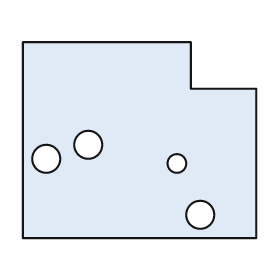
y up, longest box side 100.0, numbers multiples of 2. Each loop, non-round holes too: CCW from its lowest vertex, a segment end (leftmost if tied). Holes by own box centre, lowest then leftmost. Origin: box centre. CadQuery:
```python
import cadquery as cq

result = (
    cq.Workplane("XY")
    .moveTo(-50.0, -42.0)
    .lineTo(50.0, -42.0)
    .lineTo(50.0, 22.0)
    .lineTo(22.0, 22.0)
    .lineTo(22.0, 42.0)
    .lineTo(-50.0, 42.0)
    .close()
    .moveTo(26.0, -32.0)
    .circle(6.0)
    .moveTo(16.0, -10.0)
    .circle(4.0)
    .moveTo(-40.0, -8.0)
    .circle(6.0)
    .moveTo(-22.0, -2.0)
    .circle(6.0)
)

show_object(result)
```